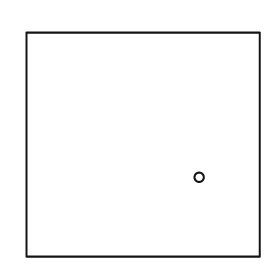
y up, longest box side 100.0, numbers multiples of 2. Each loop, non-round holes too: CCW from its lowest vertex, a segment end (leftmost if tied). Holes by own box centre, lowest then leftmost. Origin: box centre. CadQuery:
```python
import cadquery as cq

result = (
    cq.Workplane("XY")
    .moveTo(-50.0, -48.0)
    .lineTo(50.0, -48.0)
    .lineTo(50.0, 48.0)
    .lineTo(-50.0, 48.0)
    .close()
    .moveTo(24.0, -14.0)
    .circle(2.0)
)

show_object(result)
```